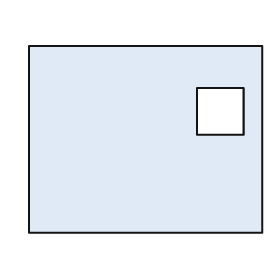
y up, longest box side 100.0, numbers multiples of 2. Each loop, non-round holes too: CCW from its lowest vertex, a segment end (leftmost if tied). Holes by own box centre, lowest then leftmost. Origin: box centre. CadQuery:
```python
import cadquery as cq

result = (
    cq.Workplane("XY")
    .moveTo(-50.0, -40.0)
    .lineTo(50.0, -40.0)
    .lineTo(50.0, 40.0)
    .lineTo(-50.0, 40.0)
    .close()
    .moveTo(22.0, 2.0)
    .lineTo(42.0, 2.0)
    .lineTo(42.0, 22.0)
    .lineTo(22.0, 22.0)
    .close()
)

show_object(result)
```